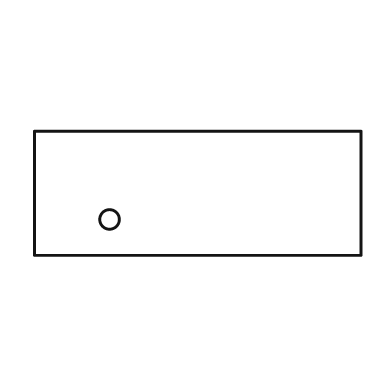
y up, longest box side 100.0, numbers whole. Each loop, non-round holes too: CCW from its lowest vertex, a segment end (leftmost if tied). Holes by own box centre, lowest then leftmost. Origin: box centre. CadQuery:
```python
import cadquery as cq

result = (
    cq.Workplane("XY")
    .moveTo(-50.0, -19.0)
    .lineTo(50.0, -19.0)
    .lineTo(50.0, 19.0)
    .lineTo(-50.0, 19.0)
    .close()
    .moveTo(-27.0, -8.0)
    .circle(3.0)
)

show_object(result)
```